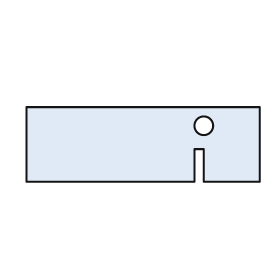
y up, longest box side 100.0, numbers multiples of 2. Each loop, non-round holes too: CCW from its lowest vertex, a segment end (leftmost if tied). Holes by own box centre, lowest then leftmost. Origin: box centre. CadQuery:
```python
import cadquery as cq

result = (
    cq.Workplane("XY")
    .moveTo(-50.0, -16.0)
    .lineTo(22.0, -16.0)
    .lineTo(22.0, -2.0)
    .lineTo(26.0, -2.0)
    .lineTo(26.0, -16.0)
    .lineTo(50.0, -16.0)
    .lineTo(50.0, 16.0)
    .lineTo(-50.0, 16.0)
    .close()
    .moveTo(26.0, 8.0)
    .circle(4.0)
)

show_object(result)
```